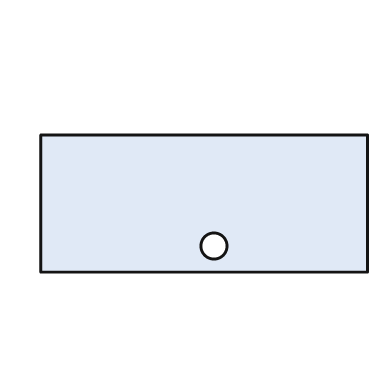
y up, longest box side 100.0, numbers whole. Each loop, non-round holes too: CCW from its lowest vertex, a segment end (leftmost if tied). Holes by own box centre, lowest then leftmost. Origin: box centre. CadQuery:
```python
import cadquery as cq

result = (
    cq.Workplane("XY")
    .moveTo(-50.0, -21.0)
    .lineTo(50.0, -21.0)
    .lineTo(50.0, 21.0)
    .lineTo(-50.0, 21.0)
    .close()
    .moveTo(3.0, -13.0)
    .circle(4.0)
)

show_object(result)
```